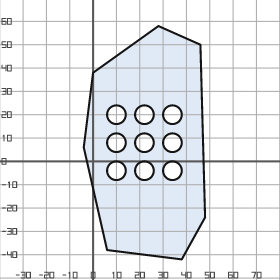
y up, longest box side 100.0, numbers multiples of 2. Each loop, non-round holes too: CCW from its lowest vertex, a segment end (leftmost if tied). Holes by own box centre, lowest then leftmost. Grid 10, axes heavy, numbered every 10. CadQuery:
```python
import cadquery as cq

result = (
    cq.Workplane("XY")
    .moveTo(38.0, -42.0)
    .lineTo(48.0, -24.0)
    .lineTo(46.0, 50.0)
    .lineTo(28.0, 58.0)
    .lineTo(0.0, 38.0)
    .lineTo(-4.0, 6.0)
    .lineTo(6.0, -38.0)
    .close()
    .moveTo(10.0, -4.0)
    .circle(4.0)
    .moveTo(22.0, -4.0)
    .circle(4.0)
    .moveTo(34.0, -4.0)
    .circle(4.0)
    .moveTo(10.0, 8.0)
    .circle(4.0)
    .moveTo(22.0, 8.0)
    .circle(4.0)
    .moveTo(34.0, 8.0)
    .circle(4.0)
    .moveTo(10.0, 20.0)
    .circle(4.0)
    .moveTo(22.0, 20.0)
    .circle(4.0)
    .moveTo(34.0, 20.0)
    .circle(4.0)
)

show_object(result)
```